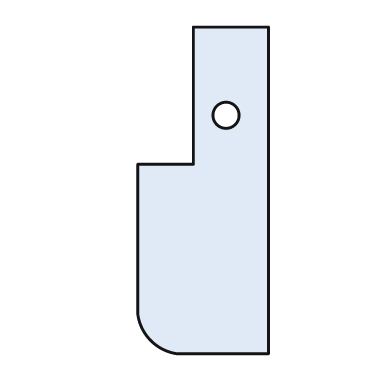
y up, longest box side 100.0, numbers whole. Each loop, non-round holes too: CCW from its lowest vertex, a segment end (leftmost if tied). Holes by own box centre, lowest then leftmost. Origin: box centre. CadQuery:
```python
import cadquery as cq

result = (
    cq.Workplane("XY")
    .moveTo(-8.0, -50.0)
    .lineTo(20.0, -50.0)
    .lineTo(20.0, 50.0)
    .lineTo(-3.0, 50.0)
    .lineTo(-3.0, 8.0)
    .lineTo(-20.0, 8.0)
    .lineTo(-20.0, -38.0)
    .threePointArc((-16.0, -46.0), (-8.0, -50.0))
    .close()
    .moveTo(7.0, 23.0)
    .circle(4.0)
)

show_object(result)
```